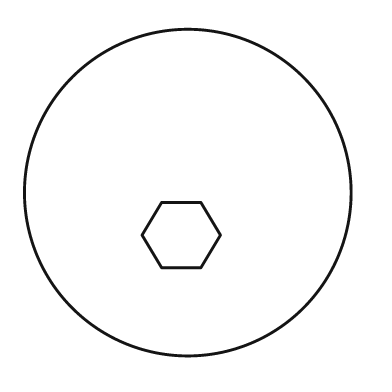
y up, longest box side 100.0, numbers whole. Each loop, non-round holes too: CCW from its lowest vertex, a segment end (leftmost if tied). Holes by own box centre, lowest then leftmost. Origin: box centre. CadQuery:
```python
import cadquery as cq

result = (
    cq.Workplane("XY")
    .moveTo(0.0, 0.0)
    .circle(50.0)
    .moveTo(-8.0, -23.0)
    .lineTo(4.0, -23.0)
    .lineTo(10.0, -13.0)
    .lineTo(4.0, -3.0)
    .lineTo(-8.0, -3.0)
    .lineTo(-14.0, -13.0)
    .close()
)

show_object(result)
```